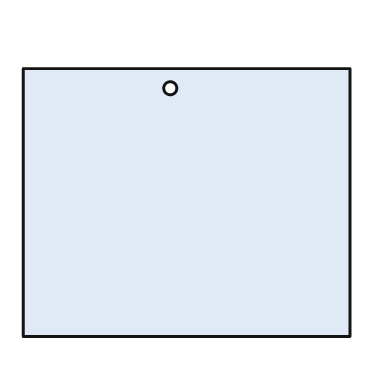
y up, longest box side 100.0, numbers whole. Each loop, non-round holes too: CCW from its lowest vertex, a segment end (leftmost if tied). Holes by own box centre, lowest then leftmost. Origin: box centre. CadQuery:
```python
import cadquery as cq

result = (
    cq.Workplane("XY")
    .moveTo(-50.0, -41.0)
    .lineTo(50.0, -41.0)
    .lineTo(50.0, 41.0)
    .lineTo(-50.0, 41.0)
    .close()
    .moveTo(-5.0, 35.0)
    .circle(2.0)
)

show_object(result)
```